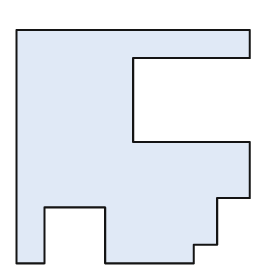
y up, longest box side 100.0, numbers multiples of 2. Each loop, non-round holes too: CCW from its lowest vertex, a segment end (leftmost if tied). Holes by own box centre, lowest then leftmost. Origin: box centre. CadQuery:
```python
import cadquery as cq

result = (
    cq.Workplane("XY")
    .moveTo(-50.0, -50.0)
    .lineTo(-38.0, -50.0)
    .lineTo(-38.0, -26.0)
    .lineTo(-12.0, -26.0)
    .lineTo(-12.0, -50.0)
    .lineTo(26.0, -50.0)
    .lineTo(26.0, -42.0)
    .lineTo(36.0, -42.0)
    .lineTo(36.0, -22.0)
    .lineTo(50.0, -22.0)
    .lineTo(50.0, 2.0)
    .lineTo(0.0, 2.0)
    .lineTo(0.0, 38.0)
    .lineTo(50.0, 38.0)
    .lineTo(50.0, 50.0)
    .lineTo(-50.0, 50.0)
    .close()
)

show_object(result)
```